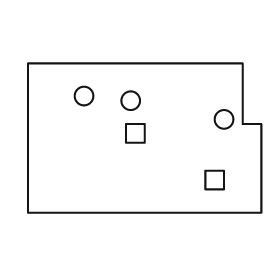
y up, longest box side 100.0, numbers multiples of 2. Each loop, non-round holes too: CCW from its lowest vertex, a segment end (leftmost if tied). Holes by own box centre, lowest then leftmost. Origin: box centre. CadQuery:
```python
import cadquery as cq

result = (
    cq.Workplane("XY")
    .moveTo(-50.0, -32.0)
    .lineTo(50.0, -32.0)
    .lineTo(50.0, 6.0)
    .lineTo(42.0, 6.0)
    .lineTo(42.0, 32.0)
    .lineTo(-50.0, 32.0)
    .close()
    .moveTo(26.0, -22.0)
    .lineTo(34.0, -22.0)
    .lineTo(34.0, -14.0)
    .lineTo(26.0, -14.0)
    .close()
    .moveTo(-8.0, -2.0)
    .lineTo(0.0, -2.0)
    .lineTo(0.0, 6.0)
    .lineTo(-8.0, 6.0)
    .close()
    .moveTo(34.0, 8.0)
    .circle(4.0)
    .moveTo(-6.0, 16.0)
    .circle(4.0)
    .moveTo(-26.0, 18.0)
    .circle(4.0)
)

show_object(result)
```